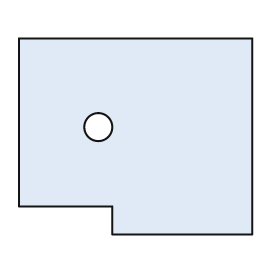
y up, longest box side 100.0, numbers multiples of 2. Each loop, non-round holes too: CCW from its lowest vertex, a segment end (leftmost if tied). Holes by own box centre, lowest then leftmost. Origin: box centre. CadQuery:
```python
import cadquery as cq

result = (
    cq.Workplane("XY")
    .moveTo(-10.0, -42.0)
    .lineTo(50.0, -42.0)
    .lineTo(50.0, 42.0)
    .lineTo(-50.0, 42.0)
    .lineTo(-50.0, -30.0)
    .lineTo(-10.0, -30.0)
    .close()
    .moveTo(-16.0, 4.0)
    .circle(6.0)
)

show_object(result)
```